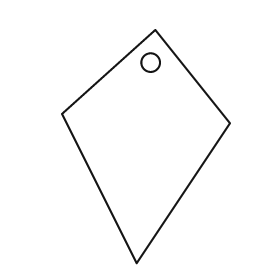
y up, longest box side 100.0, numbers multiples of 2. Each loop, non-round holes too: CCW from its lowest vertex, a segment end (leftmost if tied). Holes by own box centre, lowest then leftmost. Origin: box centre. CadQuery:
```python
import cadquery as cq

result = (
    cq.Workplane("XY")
    .moveTo(-4.0, -50.0)
    .lineTo(36.0, 10.0)
    .lineTo(4.0, 50.0)
    .lineTo(-36.0, 14.0)
    .close()
    .moveTo(2.0, 36.0)
    .circle(4.0)
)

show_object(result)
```